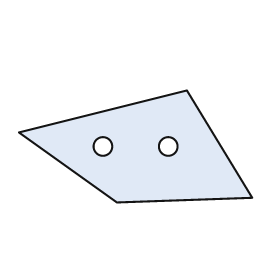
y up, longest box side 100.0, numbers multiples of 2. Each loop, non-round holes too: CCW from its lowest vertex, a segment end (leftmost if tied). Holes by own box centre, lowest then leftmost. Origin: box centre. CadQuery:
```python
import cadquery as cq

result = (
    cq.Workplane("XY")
    .moveTo(-8.0, -24.0)
    .lineTo(50.0, -22.0)
    .lineTo(22.0, 24.0)
    .lineTo(-50.0, 6.0)
    .close()
    .moveTo(-14.0, 0.0)
    .circle(4.0)
    .moveTo(14.0, 0.0)
    .circle(4.0)
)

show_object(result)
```